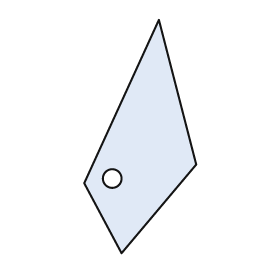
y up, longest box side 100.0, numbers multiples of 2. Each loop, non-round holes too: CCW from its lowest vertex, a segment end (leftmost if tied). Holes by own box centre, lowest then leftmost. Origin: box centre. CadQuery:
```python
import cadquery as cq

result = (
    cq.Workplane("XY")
    .moveTo(-8.0, -50.0)
    .lineTo(24.0, -12.0)
    .lineTo(8.0, 50.0)
    .lineTo(-24.0, -20.0)
    .close()
    .moveTo(-12.0, -18.0)
    .circle(4.0)
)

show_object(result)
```